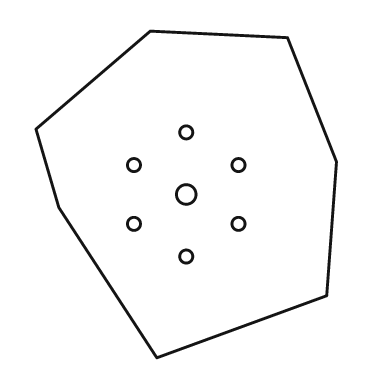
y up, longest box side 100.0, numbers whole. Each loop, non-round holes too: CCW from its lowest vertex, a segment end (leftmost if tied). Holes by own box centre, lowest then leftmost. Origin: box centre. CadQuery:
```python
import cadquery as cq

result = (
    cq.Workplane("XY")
    .moveTo(-9.0, -50.0)
    .lineTo(43.0, -31.0)
    .lineTo(46.0, 10.0)
    .lineTo(31.0, 48.0)
    .lineTo(-11.0, 50.0)
    .lineTo(-46.0, 20.0)
    .lineTo(-39.0, -4.0)
    .close()
    .moveTo(0.0, -19.0)
    .circle(2.0)
    .moveTo(-16.0, -9.0)
    .circle(2.0)
    .moveTo(16.0, -9.0)
    .circle(2.0)
    .moveTo(0.0, 0.0)
    .circle(3.0)
    .moveTo(-16.0, 9.0)
    .circle(2.0)
    .moveTo(16.0, 9.0)
    .circle(2.0)
    .moveTo(0.0, 19.0)
    .circle(2.0)
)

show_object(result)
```